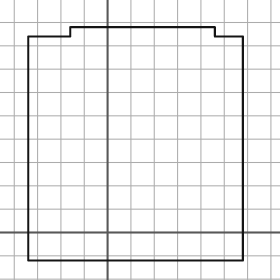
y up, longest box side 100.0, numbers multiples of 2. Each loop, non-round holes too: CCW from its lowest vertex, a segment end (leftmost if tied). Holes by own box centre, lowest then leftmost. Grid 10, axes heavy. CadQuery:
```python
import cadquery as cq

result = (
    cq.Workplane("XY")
    .moveTo(-34.0, -12.0)
    .lineTo(58.0, -12.0)
    .lineTo(58.0, 84.0)
    .lineTo(46.0, 84.0)
    .lineTo(46.0, 88.0)
    .lineTo(-16.0, 88.0)
    .lineTo(-16.0, 84.0)
    .lineTo(-34.0, 84.0)
    .close()
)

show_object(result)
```